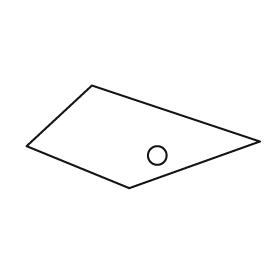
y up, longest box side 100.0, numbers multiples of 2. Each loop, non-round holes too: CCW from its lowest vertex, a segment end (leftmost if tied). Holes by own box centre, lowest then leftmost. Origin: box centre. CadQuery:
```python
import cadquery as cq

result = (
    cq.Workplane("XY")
    .moveTo(-6.0, -22.0)
    .lineTo(50.0, -2.0)
    .lineTo(-22.0, 22.0)
    .lineTo(-50.0, -4.0)
    .close()
    .moveTo(6.0, -8.0)
    .circle(4.0)
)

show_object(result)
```